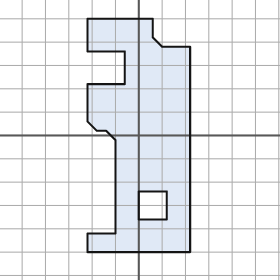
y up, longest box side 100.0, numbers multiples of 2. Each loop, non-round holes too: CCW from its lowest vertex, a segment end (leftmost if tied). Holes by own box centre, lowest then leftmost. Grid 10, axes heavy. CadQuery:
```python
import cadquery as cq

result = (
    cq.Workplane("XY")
    .moveTo(-22.0, -50.0)
    .lineTo(22.0, -50.0)
    .lineTo(22.0, 38.0)
    .lineTo(10.0, 38.0)
    .lineTo(6.0, 42.0)
    .lineTo(6.0, 50.0)
    .lineTo(-22.0, 50.0)
    .lineTo(-22.0, 36.0)
    .lineTo(-6.0, 36.0)
    .lineTo(-6.0, 22.0)
    .lineTo(-22.0, 22.0)
    .lineTo(-22.0, 6.0)
    .lineTo(-18.0, 2.0)
    .lineTo(-14.0, 2.0)
    .lineTo(-10.0, -2.0)
    .lineTo(-10.0, -42.0)
    .lineTo(-22.0, -42.0)
    .close()
    .moveTo(0.0, -36.0)
    .lineTo(12.0, -36.0)
    .lineTo(12.0, -24.0)
    .lineTo(0.0, -24.0)
    .close()
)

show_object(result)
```